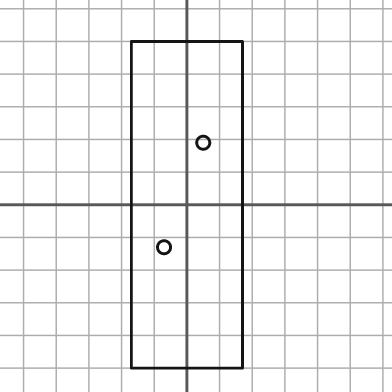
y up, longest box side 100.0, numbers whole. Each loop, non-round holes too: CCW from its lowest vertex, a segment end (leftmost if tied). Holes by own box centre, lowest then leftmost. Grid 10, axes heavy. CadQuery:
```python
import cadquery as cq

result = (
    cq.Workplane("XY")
    .moveTo(-17.0, -50.0)
    .lineTo(17.0, -50.0)
    .lineTo(17.0, 50.0)
    .lineTo(-17.0, 50.0)
    .close()
    .moveTo(-7.0, -13.0)
    .circle(2.0)
    .moveTo(5.0, 19.0)
    .circle(2.0)
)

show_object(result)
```